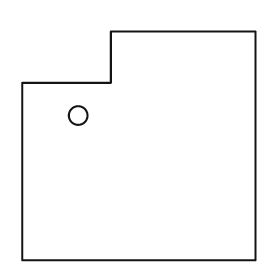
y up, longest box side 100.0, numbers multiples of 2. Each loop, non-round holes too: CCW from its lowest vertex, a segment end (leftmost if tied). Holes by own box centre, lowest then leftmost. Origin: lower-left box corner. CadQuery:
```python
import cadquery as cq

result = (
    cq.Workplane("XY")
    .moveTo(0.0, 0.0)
    .lineTo(100.0, 0.0)
    .lineTo(100.0, 98.0)
    .lineTo(38.0, 98.0)
    .lineTo(38.0, 76.0)
    .lineTo(0.0, 76.0)
    .close()
    .moveTo(24.0, 62.0)
    .circle(4.0)
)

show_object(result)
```